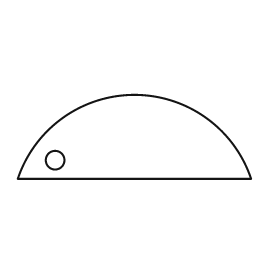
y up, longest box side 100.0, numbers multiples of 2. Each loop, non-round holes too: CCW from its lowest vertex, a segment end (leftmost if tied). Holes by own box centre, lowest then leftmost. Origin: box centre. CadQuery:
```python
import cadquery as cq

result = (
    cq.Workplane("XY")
    .moveTo(-50.0, -18.0)
    .lineTo(50.0, -18.0)
    .threePointArc((0.0, 18.0), (-50.0, -18.0))
    .close()
    .moveTo(-34.0, -10.0)
    .circle(4.0)
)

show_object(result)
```